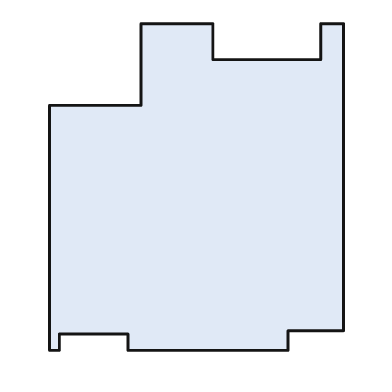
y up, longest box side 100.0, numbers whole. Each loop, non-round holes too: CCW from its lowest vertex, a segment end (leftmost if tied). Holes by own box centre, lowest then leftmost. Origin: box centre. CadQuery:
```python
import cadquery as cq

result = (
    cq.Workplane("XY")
    .moveTo(-45.0, -50.0)
    .lineTo(-42.0, -50.0)
    .lineTo(-42.0, -45.0)
    .lineTo(-21.0, -45.0)
    .lineTo(-21.0, -50.0)
    .lineTo(28.0, -50.0)
    .lineTo(28.0, -44.0)
    .lineTo(45.0, -44.0)
    .lineTo(45.0, 50.0)
    .lineTo(38.0, 50.0)
    .lineTo(38.0, 39.0)
    .lineTo(5.0, 39.0)
    .lineTo(5.0, 50.0)
    .lineTo(-17.0, 50.0)
    .lineTo(-17.0, 25.0)
    .lineTo(-45.0, 25.0)
    .close()
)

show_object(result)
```